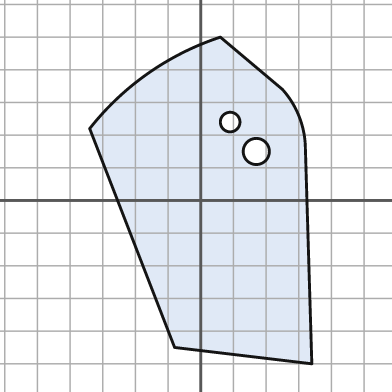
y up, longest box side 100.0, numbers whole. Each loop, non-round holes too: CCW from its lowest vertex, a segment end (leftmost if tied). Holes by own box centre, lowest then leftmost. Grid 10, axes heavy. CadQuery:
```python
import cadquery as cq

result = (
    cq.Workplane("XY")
    .moveTo(34.0, -50.0)
    .lineTo(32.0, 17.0)
    .threePointArc((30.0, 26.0), (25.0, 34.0))
    .lineTo(6.0, 50.0)
    .threePointArc((-16.0, 39.0), (-34.0, 22.0))
    .lineTo(-8.0, -45.0)
    .close()
    .moveTo(17.0, 15.0)
    .circle(4.0)
    .moveTo(9.0, 24.0)
    .circle(3.0)
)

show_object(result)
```